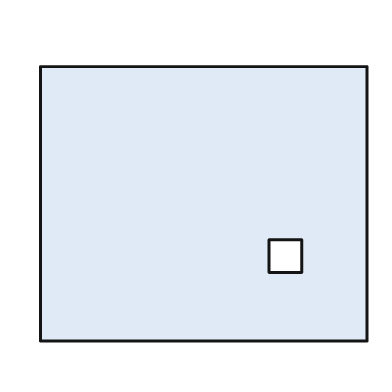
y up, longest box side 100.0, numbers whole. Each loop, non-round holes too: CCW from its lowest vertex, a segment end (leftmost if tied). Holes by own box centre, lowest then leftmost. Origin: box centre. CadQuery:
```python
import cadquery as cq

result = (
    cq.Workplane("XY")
    .moveTo(-50.0, -42.0)
    .lineTo(50.0, -42.0)
    .lineTo(50.0, 42.0)
    .lineTo(-50.0, 42.0)
    .close()
    .moveTo(20.0, -21.0)
    .lineTo(30.0, -21.0)
    .lineTo(30.0, -11.0)
    .lineTo(20.0, -11.0)
    .close()
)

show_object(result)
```